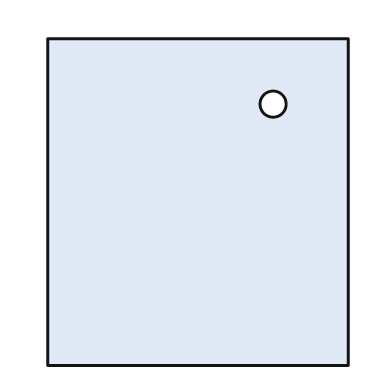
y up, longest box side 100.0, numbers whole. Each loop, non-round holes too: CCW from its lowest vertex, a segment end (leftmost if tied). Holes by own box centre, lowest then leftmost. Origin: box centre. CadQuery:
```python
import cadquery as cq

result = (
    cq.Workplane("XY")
    .moveTo(-46.0, -50.0)
    .lineTo(46.0, -50.0)
    .lineTo(46.0, 50.0)
    .lineTo(-46.0, 50.0)
    .close()
    .moveTo(23.0, 30.0)
    .circle(4.0)
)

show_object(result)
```